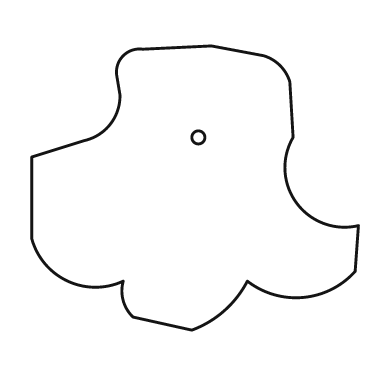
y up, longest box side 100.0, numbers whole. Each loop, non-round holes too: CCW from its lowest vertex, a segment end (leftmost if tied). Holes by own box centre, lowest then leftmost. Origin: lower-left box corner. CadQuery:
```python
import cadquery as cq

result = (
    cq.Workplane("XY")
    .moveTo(49.0, 0.0)
    .threePointArc((59.0, 6.0), (66.0, 15.0))
    .threePointArc((83.0, 10.0), (99.0, 18.0))
    .lineTo(100.0, 32.0)
    .threePointArc((81.0, 39.0), (80.0, 59.0))
    .lineTo(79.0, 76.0)
    .threePointArc((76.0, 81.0), (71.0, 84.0))
    .lineTo(55.0, 87.0)
    .lineTo(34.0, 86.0)
    .threePointArc((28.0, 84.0), (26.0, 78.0))
    .lineTo(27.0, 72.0)
    .threePointArc((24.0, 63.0), (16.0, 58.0))
    .lineTo(0.0, 53.0)
    .lineTo(0.0, 28.0)
    .threePointArc((11.0, 15.0), (28.0, 15.0))
    .threePointArc((28.0, 9.0), (31.0, 4.0))
    .close()
    .moveTo(51.0, 59.0)
    .circle(2.0)
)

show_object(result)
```